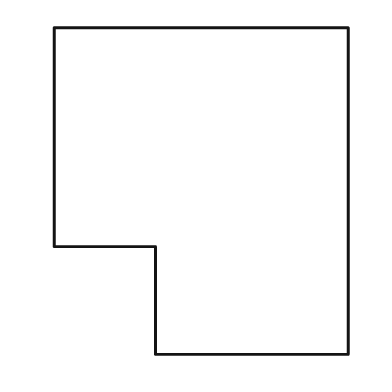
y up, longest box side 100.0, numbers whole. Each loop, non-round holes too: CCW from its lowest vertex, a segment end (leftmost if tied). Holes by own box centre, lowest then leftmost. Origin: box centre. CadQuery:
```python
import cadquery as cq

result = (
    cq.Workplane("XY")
    .moveTo(-14.0, -50.0)
    .lineTo(45.0, -50.0)
    .lineTo(45.0, 50.0)
    .lineTo(-45.0, 50.0)
    .lineTo(-45.0, -17.0)
    .lineTo(-14.0, -17.0)
    .close()
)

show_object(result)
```